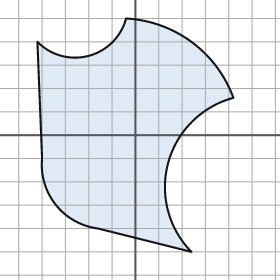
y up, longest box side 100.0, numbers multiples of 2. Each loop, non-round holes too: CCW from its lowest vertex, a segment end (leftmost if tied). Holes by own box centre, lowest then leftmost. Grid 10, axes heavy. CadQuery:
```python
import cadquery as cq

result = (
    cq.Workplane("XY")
    .moveTo(24.0, -50.0)
    .threePointArc((14.0, -12.0), (42.0, 16.0))
    .threePointArc((24.0, 40.0), (-4.0, 50.0))
    .threePointArc((-20.0, 34.0), (-42.0, 40.0))
    .lineTo(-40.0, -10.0)
    .threePointArc((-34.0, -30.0), (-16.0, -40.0))
    .close()
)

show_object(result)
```